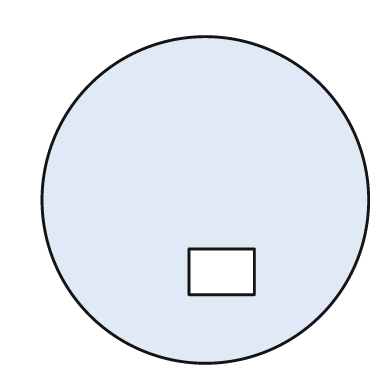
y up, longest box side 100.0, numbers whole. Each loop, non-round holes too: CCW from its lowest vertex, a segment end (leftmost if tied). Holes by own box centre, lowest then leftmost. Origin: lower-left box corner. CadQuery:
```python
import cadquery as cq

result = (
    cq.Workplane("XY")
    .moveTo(50.0, 50.0)
    .circle(50.0)
    .moveTo(45.0, 21.0)
    .lineTo(65.0, 21.0)
    .lineTo(65.0, 35.0)
    .lineTo(45.0, 35.0)
    .close()
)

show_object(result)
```